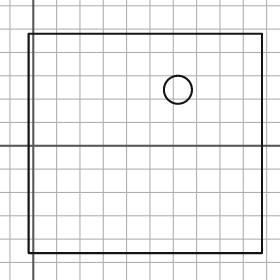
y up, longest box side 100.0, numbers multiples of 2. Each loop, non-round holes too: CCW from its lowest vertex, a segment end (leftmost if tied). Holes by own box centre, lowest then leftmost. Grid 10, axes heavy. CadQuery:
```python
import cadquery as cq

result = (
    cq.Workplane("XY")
    .moveTo(-2.0, -46.0)
    .lineTo(98.0, -46.0)
    .lineTo(98.0, 48.0)
    .lineTo(-2.0, 48.0)
    .close()
    .moveTo(62.0, 24.0)
    .circle(6.0)
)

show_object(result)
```